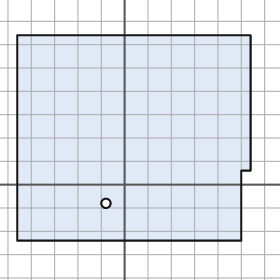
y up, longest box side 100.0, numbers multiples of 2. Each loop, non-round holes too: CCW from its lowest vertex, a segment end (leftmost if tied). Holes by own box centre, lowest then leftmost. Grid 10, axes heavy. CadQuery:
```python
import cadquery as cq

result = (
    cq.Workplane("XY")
    .moveTo(-46.0, -24.0)
    .lineTo(50.0, -24.0)
    .lineTo(50.0, 6.0)
    .lineTo(54.0, 6.0)
    .lineTo(54.0, 64.0)
    .lineTo(-46.0, 64.0)
    .close()
    .moveTo(-8.0, -8.0)
    .circle(2.0)
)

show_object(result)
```